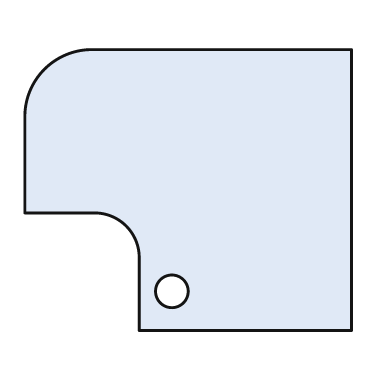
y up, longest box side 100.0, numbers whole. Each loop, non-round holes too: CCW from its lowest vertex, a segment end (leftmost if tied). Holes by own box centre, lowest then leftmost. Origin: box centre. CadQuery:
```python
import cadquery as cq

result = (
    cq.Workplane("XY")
    .moveTo(-15.0, -43.0)
    .lineTo(50.0, -43.0)
    .lineTo(50.0, 43.0)
    .lineTo(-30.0, 43.0)
    .threePointArc((-44.0, 37.0), (-50.0, 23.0))
    .lineTo(-50.0, -7.0)
    .lineTo(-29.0, -7.0)
    .threePointArc((-19.0, -11.0), (-15.0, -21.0))
    .close()
    .moveTo(-5.0, -31.0)
    .circle(5.0)
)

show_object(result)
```